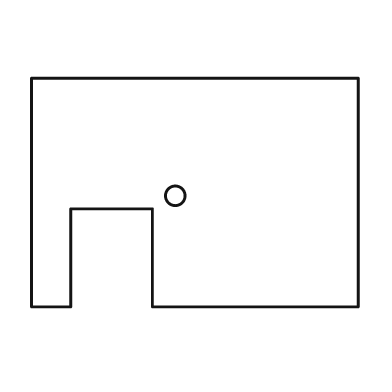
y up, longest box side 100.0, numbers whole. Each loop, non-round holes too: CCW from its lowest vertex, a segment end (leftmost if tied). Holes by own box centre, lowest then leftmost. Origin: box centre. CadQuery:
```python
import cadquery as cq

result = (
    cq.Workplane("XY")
    .moveTo(-50.0, -35.0)
    .lineTo(-38.0, -35.0)
    .lineTo(-38.0, -5.0)
    .lineTo(-13.0, -5.0)
    .lineTo(-13.0, -35.0)
    .lineTo(50.0, -35.0)
    .lineTo(50.0, 35.0)
    .lineTo(-50.0, 35.0)
    .close()
    .moveTo(-6.0, -1.0)
    .circle(3.0)
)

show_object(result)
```